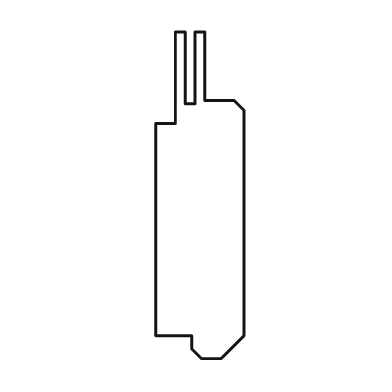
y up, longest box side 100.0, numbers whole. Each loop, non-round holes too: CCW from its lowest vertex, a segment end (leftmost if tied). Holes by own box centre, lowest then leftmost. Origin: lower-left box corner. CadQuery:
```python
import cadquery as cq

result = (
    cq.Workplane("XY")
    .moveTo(14.0, 0.0)
    .lineTo(20.0, 0.0)
    .lineTo(27.0, 7.0)
    .lineTo(27.0, 76.0)
    .lineTo(24.0, 79.0)
    .lineTo(15.0, 79.0)
    .lineTo(15.0, 100.0)
    .lineTo(12.0, 100.0)
    .lineTo(12.0, 78.0)
    .lineTo(9.0, 78.0)
    .lineTo(9.0, 100.0)
    .lineTo(6.0, 100.0)
    .lineTo(6.0, 72.0)
    .lineTo(0.0, 72.0)
    .lineTo(0.0, 7.0)
    .lineTo(11.0, 7.0)
    .lineTo(11.0, 3.0)
    .close()
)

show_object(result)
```